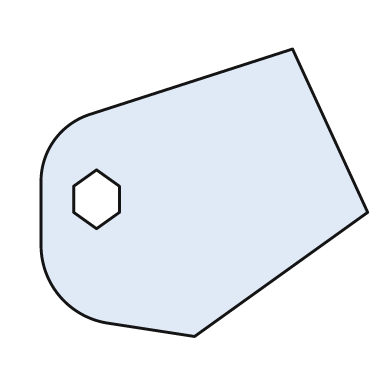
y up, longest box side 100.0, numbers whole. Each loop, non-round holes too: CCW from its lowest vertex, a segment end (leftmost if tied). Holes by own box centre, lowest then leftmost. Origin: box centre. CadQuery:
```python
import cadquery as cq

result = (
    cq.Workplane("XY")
    .moveTo(-3.0, -44.0)
    .lineTo(50.0, -6.0)
    .lineTo(27.0, 44.0)
    .lineTo(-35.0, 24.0)
    .threePointArc((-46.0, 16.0), (-50.0, 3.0))
    .lineTo(-50.0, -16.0)
    .threePointArc((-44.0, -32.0), (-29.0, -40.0))
    .close()
    .moveTo(-33.0, -11.0)
    .lineTo(-26.0, -6.0)
    .lineTo(-26.0, 2.0)
    .lineTo(-33.0, 7.0)
    .lineTo(-40.0, 2.0)
    .lineTo(-40.0, -6.0)
    .close()
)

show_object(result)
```